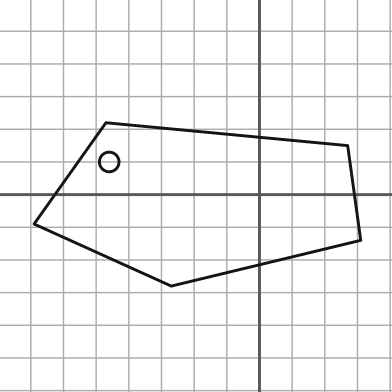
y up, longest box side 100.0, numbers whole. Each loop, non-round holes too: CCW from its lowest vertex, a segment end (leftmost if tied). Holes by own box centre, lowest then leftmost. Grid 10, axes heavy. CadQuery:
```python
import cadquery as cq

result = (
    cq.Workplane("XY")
    .moveTo(-27.0, -28.0)
    .lineTo(31.0, -14.0)
    .lineTo(27.0, 15.0)
    .lineTo(-47.0, 22.0)
    .lineTo(-69.0, -9.0)
    .close()
    .moveTo(-46.0, 10.0)
    .circle(3.0)
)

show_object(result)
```